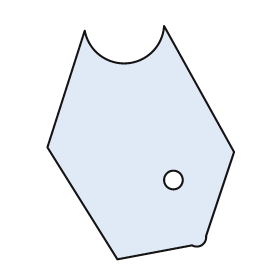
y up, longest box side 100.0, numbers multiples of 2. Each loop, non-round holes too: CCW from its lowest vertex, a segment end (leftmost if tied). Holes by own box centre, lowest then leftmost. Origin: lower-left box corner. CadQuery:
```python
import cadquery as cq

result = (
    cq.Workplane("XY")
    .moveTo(30.0, 0.0)
    .lineTo(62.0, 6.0)
    .threePointArc((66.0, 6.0), (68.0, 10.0))
    .lineTo(80.0, 46.0)
    .lineTo(50.0, 100.0)
    .threePointArc((34.0, 84.0), (16.0, 98.0))
    .lineTo(0.0, 48.0)
    .close()
    .moveTo(54.0, 34.0)
    .circle(4.0)
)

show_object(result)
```